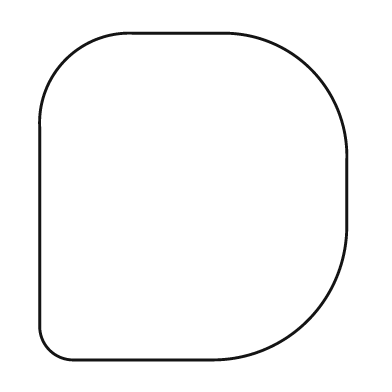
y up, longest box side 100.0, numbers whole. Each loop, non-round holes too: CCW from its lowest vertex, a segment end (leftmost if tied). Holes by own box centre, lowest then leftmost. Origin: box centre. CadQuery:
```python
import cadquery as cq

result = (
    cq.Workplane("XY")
    .moveTo(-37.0, -50.0)
    .lineTo(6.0, -50.0)
    .threePointArc((35.0, -38.0), (47.0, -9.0))
    .lineTo(47.0, 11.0)
    .threePointArc((36.0, 39.0), (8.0, 50.0))
    .lineTo(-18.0, 50.0)
    .threePointArc((-39.0, 42.0), (-47.0, 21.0))
    .lineTo(-47.0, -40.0)
    .threePointArc((-44.0, -47.0), (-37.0, -50.0))
    .close()
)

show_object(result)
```